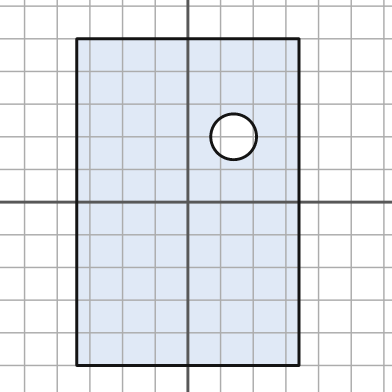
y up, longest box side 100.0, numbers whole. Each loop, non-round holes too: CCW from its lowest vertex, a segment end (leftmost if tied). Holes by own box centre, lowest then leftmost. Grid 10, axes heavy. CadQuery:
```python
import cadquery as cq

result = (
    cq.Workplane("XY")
    .moveTo(-34.0, -50.0)
    .lineTo(34.0, -50.0)
    .lineTo(34.0, 50.0)
    .lineTo(-34.0, 50.0)
    .close()
    .moveTo(14.0, 20.0)
    .circle(7.0)
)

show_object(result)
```